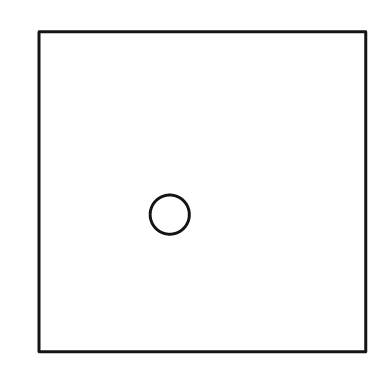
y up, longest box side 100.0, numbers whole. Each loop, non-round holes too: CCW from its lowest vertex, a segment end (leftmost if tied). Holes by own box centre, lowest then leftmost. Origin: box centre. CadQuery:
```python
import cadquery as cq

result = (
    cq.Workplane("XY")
    .moveTo(-50.0, -49.0)
    .lineTo(50.0, -49.0)
    .lineTo(50.0, 49.0)
    .lineTo(-50.0, 49.0)
    .close()
    .moveTo(-10.0, -7.0)
    .circle(6.0)
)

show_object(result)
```